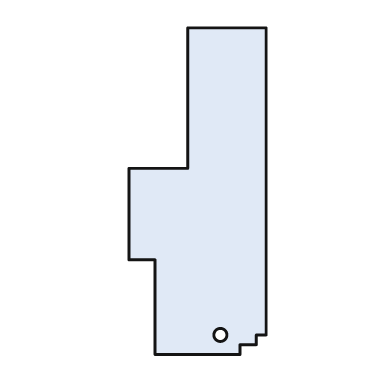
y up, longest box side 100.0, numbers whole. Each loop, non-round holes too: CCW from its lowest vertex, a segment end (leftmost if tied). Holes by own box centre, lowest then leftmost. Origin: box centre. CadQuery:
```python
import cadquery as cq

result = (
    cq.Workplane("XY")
    .moveTo(-13.0, -50.0)
    .lineTo(13.0, -50.0)
    .lineTo(13.0, -47.0)
    .lineTo(18.0, -47.0)
    .lineTo(18.0, -44.0)
    .lineTo(21.0, -44.0)
    .lineTo(21.0, 50.0)
    .lineTo(-3.0, 50.0)
    .lineTo(-3.0, 7.0)
    .lineTo(-21.0, 7.0)
    .lineTo(-21.0, -21.0)
    .lineTo(-13.0, -21.0)
    .close()
    .moveTo(7.0, -44.0)
    .circle(2.0)
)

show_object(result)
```